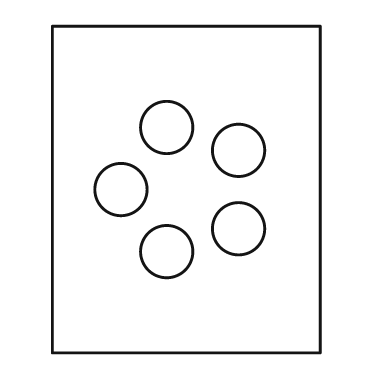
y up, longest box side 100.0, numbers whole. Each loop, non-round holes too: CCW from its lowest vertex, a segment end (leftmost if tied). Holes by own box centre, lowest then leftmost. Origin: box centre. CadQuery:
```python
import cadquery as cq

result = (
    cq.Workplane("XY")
    .moveTo(-41.0, -50.0)
    .lineTo(41.0, -50.0)
    .lineTo(41.0, 50.0)
    .lineTo(-41.0, 50.0)
    .close()
    .moveTo(-6.0, -19.0)
    .circle(8.0)
    .moveTo(16.0, -12.0)
    .circle(8.0)
    .moveTo(-20.0, 0.0)
    .circle(8.0)
    .moveTo(16.0, 12.0)
    .circle(8.0)
    .moveTo(-6.0, 19.0)
    .circle(8.0)
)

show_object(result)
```